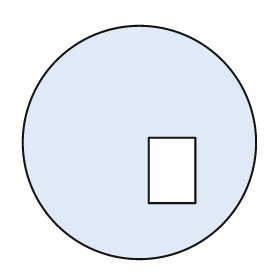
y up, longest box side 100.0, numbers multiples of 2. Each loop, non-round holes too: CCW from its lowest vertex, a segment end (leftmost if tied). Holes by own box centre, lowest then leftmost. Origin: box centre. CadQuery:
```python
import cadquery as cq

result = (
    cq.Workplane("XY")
    .moveTo(0.0, 0.0)
    .circle(50.0)
    .moveTo(4.0, -26.0)
    .lineTo(24.0, -26.0)
    .lineTo(24.0, 2.0)
    .lineTo(4.0, 2.0)
    .close()
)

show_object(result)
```